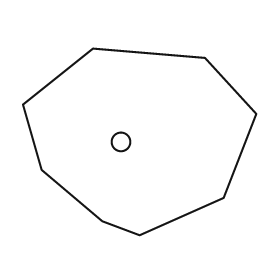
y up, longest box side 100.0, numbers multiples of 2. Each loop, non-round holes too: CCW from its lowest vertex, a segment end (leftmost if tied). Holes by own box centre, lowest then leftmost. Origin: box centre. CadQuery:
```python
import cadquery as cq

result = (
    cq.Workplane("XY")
    .moveTo(0.0, -40.0)
    .lineTo(36.0, -24.0)
    .lineTo(50.0, 12.0)
    .lineTo(28.0, 36.0)
    .lineTo(-20.0, 40.0)
    .lineTo(-50.0, 16.0)
    .lineTo(-42.0, -12.0)
    .lineTo(-16.0, -34.0)
    .close()
    .moveTo(-8.0, 0.0)
    .circle(4.0)
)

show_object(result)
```